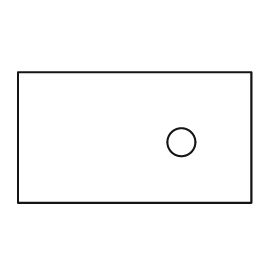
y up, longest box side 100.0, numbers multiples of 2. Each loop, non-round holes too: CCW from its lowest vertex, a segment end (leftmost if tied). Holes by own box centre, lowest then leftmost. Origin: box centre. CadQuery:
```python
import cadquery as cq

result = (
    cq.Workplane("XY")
    .moveTo(-50.0, -28.0)
    .lineTo(50.0, -28.0)
    .lineTo(50.0, 28.0)
    .lineTo(-50.0, 28.0)
    .close()
    .moveTo(20.0, -2.0)
    .circle(6.0)
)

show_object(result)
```